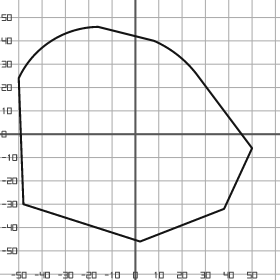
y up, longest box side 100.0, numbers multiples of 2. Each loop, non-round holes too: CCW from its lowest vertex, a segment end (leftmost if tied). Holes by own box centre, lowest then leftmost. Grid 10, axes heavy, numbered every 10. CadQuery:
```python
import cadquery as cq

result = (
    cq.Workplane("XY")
    .moveTo(2.0, -46.0)
    .lineTo(38.0, -32.0)
    .lineTo(50.0, -6.0)
    .lineTo(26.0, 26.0)
    .threePointArc((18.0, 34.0), (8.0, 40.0))
    .lineTo(-16.0, 46.0)
    .threePointArc((-36.0, 40.0), (-50.0, 24.0))
    .lineTo(-48.0, -30.0)
    .close()
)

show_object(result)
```